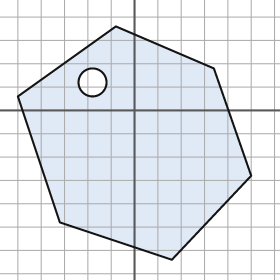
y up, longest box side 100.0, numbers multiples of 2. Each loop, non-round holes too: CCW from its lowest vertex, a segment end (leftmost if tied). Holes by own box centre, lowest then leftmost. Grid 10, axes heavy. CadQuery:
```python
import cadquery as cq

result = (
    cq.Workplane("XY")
    .moveTo(16.0, -64.0)
    .lineTo(50.0, -28.0)
    .lineTo(34.0, 18.0)
    .lineTo(-8.0, 36.0)
    .lineTo(-50.0, 6.0)
    .lineTo(-32.0, -48.0)
    .close()
    .moveTo(-18.0, 12.0)
    .circle(6.0)
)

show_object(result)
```